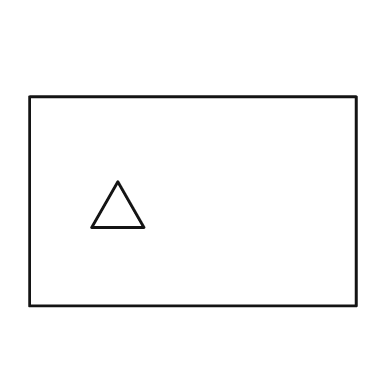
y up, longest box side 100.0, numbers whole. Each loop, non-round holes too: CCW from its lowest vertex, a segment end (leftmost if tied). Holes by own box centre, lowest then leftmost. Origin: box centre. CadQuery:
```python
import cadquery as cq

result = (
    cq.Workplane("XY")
    .moveTo(-50.0, -32.0)
    .lineTo(50.0, -32.0)
    .lineTo(50.0, 32.0)
    .lineTo(-50.0, 32.0)
    .close()
    .moveTo(-31.0, -8.0)
    .lineTo(-15.0, -8.0)
    .lineTo(-23.0, 6.0)
    .close()
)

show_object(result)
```